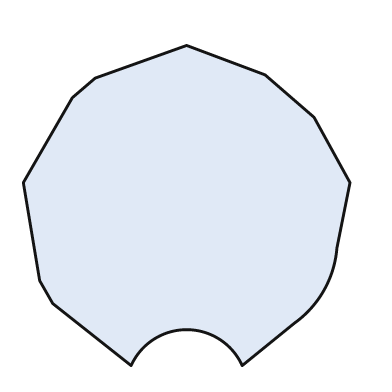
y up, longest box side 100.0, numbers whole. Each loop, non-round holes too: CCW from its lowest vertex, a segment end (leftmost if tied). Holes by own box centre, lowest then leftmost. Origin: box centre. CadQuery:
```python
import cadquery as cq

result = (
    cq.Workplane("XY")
    .moveTo(-17.0, -49.0)
    .threePointArc((0.0, -38.0), (17.0, -49.0))
    .lineTo(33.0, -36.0)
    .threePointArc((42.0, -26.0), (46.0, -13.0))
    .lineTo(50.0, 7.0)
    .lineTo(39.0, 27.0)
    .lineTo(24.0, 40.0)
    .lineTo(0.0, 49.0)
    .lineTo(-28.0, 39.0)
    .lineTo(-35.0, 33.0)
    .lineTo(-50.0, 7.0)
    .lineTo(-45.0, -23.0)
    .lineTo(-41.0, -30.0)
    .close()
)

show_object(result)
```